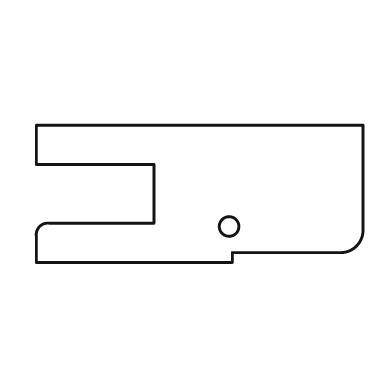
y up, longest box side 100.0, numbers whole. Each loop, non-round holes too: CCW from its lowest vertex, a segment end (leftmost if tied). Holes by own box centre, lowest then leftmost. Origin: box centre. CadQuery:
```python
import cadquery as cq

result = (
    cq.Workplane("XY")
    .moveTo(-50.0, -21.0)
    .lineTo(10.0, -21.0)
    .lineTo(10.0, -18.0)
    .lineTo(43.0, -18.0)
    .threePointArc((48.0, -16.0), (50.0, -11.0))
    .lineTo(50.0, 21.0)
    .lineTo(-50.0, 21.0)
    .lineTo(-50.0, 9.0)
    .lineTo(-14.0, 9.0)
    .lineTo(-14.0, -9.0)
    .lineTo(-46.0, -9.0)
    .threePointArc((-49.0, -10.0), (-50.0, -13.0))
    .close()
    .moveTo(9.0, -10.0)
    .circle(3.0)
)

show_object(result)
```